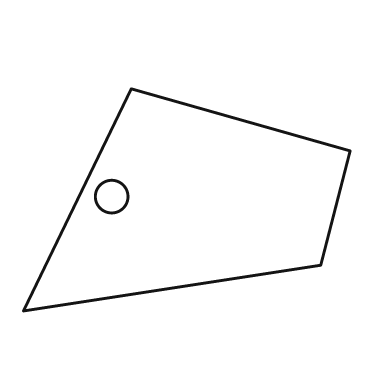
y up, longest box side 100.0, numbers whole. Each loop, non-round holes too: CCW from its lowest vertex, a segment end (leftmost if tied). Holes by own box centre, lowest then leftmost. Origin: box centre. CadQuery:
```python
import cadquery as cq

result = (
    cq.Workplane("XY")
    .moveTo(-50.0, -34.0)
    .lineTo(41.0, -20.0)
    .lineTo(50.0, 15.0)
    .lineTo(-17.0, 34.0)
    .close()
    .moveTo(-23.0, 1.0)
    .circle(5.0)
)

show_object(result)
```